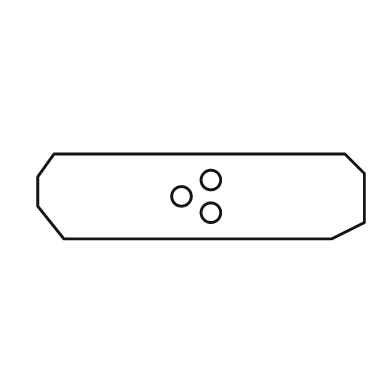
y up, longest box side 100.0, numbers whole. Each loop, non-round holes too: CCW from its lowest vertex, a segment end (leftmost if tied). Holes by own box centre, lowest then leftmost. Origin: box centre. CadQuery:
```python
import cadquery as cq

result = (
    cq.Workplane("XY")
    .moveTo(-42.0, -13.0)
    .lineTo(40.0, -13.0)
    .lineTo(50.0, -8.0)
    .lineTo(50.0, 7.0)
    .lineTo(44.0, 13.0)
    .lineTo(-45.0, 13.0)
    .lineTo(-50.0, 6.0)
    .lineTo(-50.0, -3.0)
    .close()
    .moveTo(3.0, -5.0)
    .circle(3.0)
    .moveTo(-6.0, 0.0)
    .circle(3.0)
    .moveTo(3.0, 5.0)
    .circle(3.0)
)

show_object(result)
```